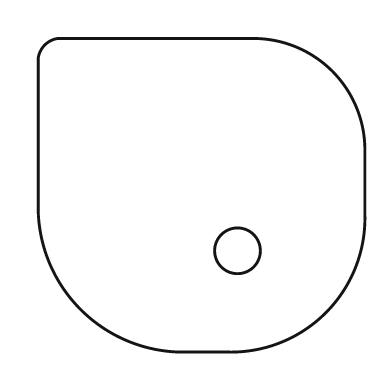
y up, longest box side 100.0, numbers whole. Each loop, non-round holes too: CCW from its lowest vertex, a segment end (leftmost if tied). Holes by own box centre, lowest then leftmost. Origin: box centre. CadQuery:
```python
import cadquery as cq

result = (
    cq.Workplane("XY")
    .moveTo(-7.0, -48.0)
    .lineTo(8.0, -48.0)
    .threePointArc((38.0, -36.0), (50.0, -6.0))
    .lineTo(50.0, 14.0)
    .threePointArc((40.0, 38.0), (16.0, 48.0))
    .lineTo(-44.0, 48.0)
    .threePointArc((-48.0, 46.0), (-50.0, 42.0))
    .lineTo(-50.0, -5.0)
    .threePointArc((-37.0, -35.0), (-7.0, -48.0))
    .close()
    .moveTo(11.0, -17.0)
    .circle(7.0)
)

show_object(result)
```